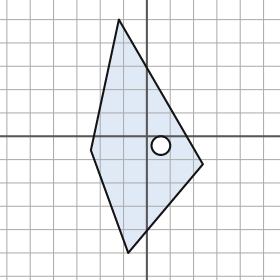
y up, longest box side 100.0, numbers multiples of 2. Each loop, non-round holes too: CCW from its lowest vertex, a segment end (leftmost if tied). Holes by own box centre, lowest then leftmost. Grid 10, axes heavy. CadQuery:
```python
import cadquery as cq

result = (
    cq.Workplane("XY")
    .moveTo(-8.0, -50.0)
    .lineTo(24.0, -12.0)
    .lineTo(-12.0, 50.0)
    .lineTo(-24.0, -6.0)
    .close()
    .moveTo(6.0, -4.0)
    .circle(4.0)
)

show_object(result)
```